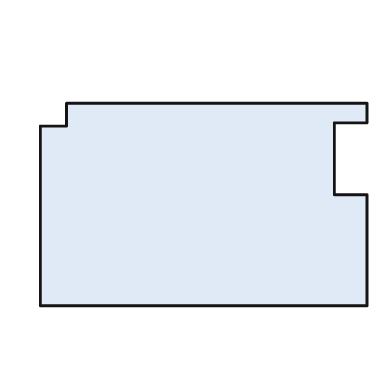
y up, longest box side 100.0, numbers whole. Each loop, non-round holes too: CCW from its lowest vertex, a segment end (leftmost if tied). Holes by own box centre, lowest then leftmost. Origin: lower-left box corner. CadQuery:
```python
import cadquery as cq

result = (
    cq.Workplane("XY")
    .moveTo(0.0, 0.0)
    .lineTo(100.0, 0.0)
    .lineTo(100.0, 34.0)
    .lineTo(90.0, 34.0)
    .lineTo(90.0, 56.0)
    .lineTo(100.0, 56.0)
    .lineTo(100.0, 62.0)
    .lineTo(8.0, 62.0)
    .lineTo(8.0, 55.0)
    .lineTo(0.0, 55.0)
    .close()
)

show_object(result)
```